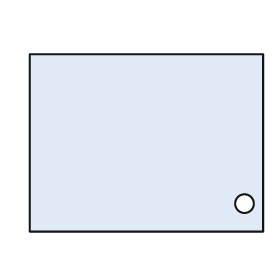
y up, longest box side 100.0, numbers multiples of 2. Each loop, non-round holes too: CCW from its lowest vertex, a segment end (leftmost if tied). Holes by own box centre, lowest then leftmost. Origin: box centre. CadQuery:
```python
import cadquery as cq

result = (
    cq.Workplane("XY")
    .moveTo(-50.0, -38.0)
    .lineTo(50.0, -38.0)
    .lineTo(50.0, 38.0)
    .lineTo(-50.0, 38.0)
    .close()
    .moveTo(42.0, -26.0)
    .circle(4.0)
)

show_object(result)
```